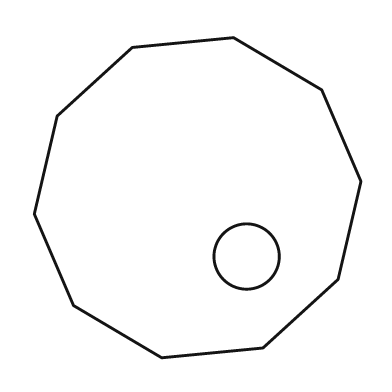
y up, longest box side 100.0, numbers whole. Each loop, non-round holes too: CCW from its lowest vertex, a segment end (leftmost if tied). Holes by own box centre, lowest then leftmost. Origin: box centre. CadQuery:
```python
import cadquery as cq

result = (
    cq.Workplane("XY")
    .moveTo(-11.0, -49.0)
    .lineTo(20.0, -46.0)
    .lineTo(43.0, -25.0)
    .lineTo(50.0, 5.0)
    .lineTo(38.0, 33.0)
    .lineTo(11.0, 49.0)
    .lineTo(-20.0, 46.0)
    .lineTo(-43.0, 25.0)
    .lineTo(-50.0, -5.0)
    .lineTo(-38.0, -33.0)
    .close()
    .moveTo(15.0, -18.0)
    .circle(10.0)
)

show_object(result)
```